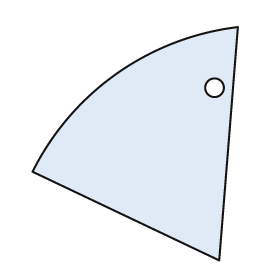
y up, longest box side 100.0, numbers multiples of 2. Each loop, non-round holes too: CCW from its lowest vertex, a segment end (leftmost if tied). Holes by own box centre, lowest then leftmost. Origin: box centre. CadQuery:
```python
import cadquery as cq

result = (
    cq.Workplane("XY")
    .moveTo(36.0, -50.0)
    .lineTo(44.0, 50.0)
    .threePointArc((-8.0, 30.0), (-44.0, -12.0))
    .close()
    .moveTo(34.0, 24.0)
    .circle(4.0)
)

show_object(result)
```